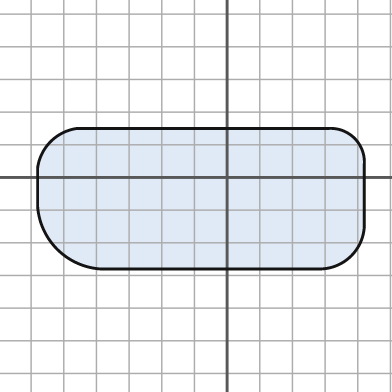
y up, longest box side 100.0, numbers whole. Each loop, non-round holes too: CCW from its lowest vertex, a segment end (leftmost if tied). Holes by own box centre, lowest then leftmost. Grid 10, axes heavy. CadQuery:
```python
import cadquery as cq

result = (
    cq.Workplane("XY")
    .moveTo(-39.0, -28.0)
    .lineTo(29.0, -28.0)
    .threePointArc((38.0, -24.0), (42.0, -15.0))
    .lineTo(42.0, 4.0)
    .threePointArc((39.0, 12.0), (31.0, 15.0))
    .lineTo(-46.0, 15.0)
    .threePointArc((-54.0, 11.0), (-58.0, 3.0))
    .lineTo(-58.0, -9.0)
    .threePointArc((-52.0, -22.0), (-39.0, -28.0))
    .close()
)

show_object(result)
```